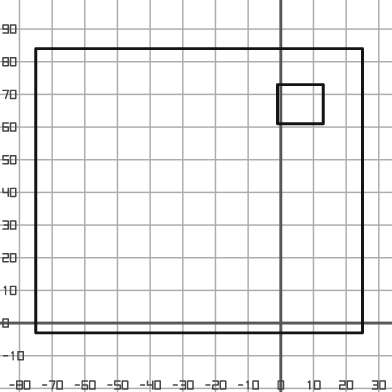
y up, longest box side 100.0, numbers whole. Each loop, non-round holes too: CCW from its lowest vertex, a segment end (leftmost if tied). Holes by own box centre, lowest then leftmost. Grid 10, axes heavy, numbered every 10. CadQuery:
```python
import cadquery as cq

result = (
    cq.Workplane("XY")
    .moveTo(-75.0, -3.0)
    .lineTo(25.0, -3.0)
    .lineTo(25.0, 84.0)
    .lineTo(-75.0, 84.0)
    .close()
    .moveTo(-1.0, 61.0)
    .lineTo(13.0, 61.0)
    .lineTo(13.0, 73.0)
    .lineTo(-1.0, 73.0)
    .close()
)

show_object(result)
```